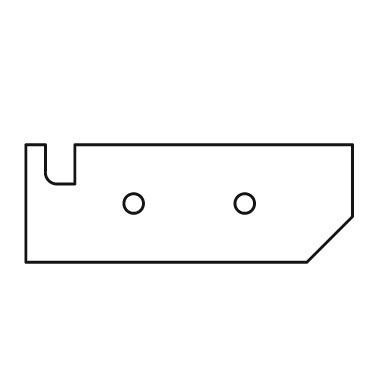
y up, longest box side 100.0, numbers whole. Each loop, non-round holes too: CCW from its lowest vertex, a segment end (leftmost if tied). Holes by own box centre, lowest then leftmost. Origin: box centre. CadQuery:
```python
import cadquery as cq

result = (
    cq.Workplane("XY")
    .moveTo(-50.0, -18.0)
    .lineTo(36.0, -18.0)
    .lineTo(50.0, -4.0)
    .lineTo(50.0, 18.0)
    .lineTo(-35.0, 18.0)
    .lineTo(-35.0, 6.0)
    .lineTo(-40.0, 6.0)
    .threePointArc((-43.0, 7.0), (-44.0, 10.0))
    .lineTo(-44.0, 18.0)
    .lineTo(-50.0, 18.0)
    .close()
    .moveTo(-17.0, 0.0)
    .circle(3.0)
    .moveTo(17.0, 0.0)
    .circle(3.0)
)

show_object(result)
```